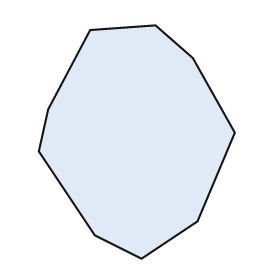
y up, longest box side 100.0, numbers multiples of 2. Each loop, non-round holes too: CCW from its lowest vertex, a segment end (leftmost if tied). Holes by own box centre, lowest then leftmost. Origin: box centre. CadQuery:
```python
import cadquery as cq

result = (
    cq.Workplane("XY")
    .moveTo(2.0, -50.0)
    .lineTo(26.0, -34.0)
    .lineTo(42.0, 4.0)
    .lineTo(24.0, 36.0)
    .lineTo(8.0, 50.0)
    .lineTo(-20.0, 48.0)
    .lineTo(-38.0, 14.0)
    .lineTo(-42.0, -4.0)
    .lineTo(-18.0, -40.0)
    .close()
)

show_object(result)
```